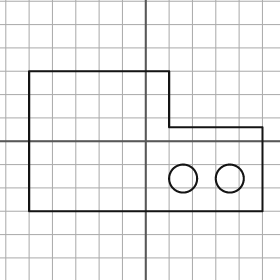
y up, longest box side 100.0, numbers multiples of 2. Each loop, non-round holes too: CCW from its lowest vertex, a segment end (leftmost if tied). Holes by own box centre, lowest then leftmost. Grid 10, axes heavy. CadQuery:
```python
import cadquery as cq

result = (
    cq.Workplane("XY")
    .moveTo(-50.0, -30.0)
    .lineTo(50.0, -30.0)
    .lineTo(50.0, 6.0)
    .lineTo(10.0, 6.0)
    .lineTo(10.0, 30.0)
    .lineTo(-50.0, 30.0)
    .close()
    .moveTo(16.0, -16.0)
    .circle(6.0)
    .moveTo(36.0, -16.0)
    .circle(6.0)
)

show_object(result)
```